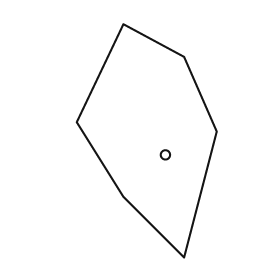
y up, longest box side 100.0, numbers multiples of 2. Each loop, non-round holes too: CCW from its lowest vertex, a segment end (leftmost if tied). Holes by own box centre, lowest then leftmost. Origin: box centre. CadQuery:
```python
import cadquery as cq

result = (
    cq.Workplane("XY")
    .moveTo(16.0, -50.0)
    .lineTo(30.0, 4.0)
    .lineTo(16.0, 36.0)
    .lineTo(-10.0, 50.0)
    .lineTo(-30.0, 8.0)
    .lineTo(-10.0, -24.0)
    .close()
    .moveTo(8.0, -6.0)
    .circle(2.0)
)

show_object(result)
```